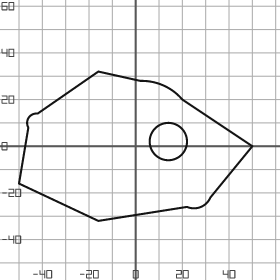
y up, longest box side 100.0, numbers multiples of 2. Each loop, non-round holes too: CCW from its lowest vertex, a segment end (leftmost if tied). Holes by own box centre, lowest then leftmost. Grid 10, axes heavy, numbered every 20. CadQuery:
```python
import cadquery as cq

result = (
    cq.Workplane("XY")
    .moveTo(-16.0, -32.0)
    .lineTo(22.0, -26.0)
    .threePointArc((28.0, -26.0), (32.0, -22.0))
    .lineTo(50.0, 0.0)
    .lineTo(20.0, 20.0)
    .threePointArc((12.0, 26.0), (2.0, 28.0))
    .lineTo(-16.0, 32.0)
    .lineTo(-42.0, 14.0)
    .threePointArc((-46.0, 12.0), (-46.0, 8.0))
    .lineTo(-50.0, -16.0)
    .close()
    .moveTo(14.0, 2.0)
    .circle(8.0)
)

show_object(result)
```